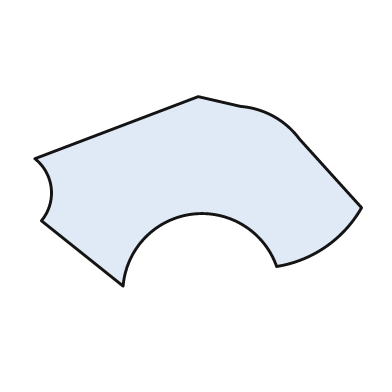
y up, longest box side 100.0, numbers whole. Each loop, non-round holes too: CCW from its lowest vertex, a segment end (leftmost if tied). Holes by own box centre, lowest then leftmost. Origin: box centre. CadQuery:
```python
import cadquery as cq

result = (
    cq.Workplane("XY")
    .moveTo(-23.0, -29.0)
    .threePointArc((-2.0, -7.0), (24.0, -23.0))
    .threePointArc((39.0, -17.0), (50.0, -5.0))
    .lineTo(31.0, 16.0)
    .threePointArc((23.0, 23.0), (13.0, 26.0))
    .lineTo(0.0, 29.0)
    .lineTo(-50.0, 10.0)
    .threePointArc((-45.0, 1.0), (-48.0, -9.0))
    .close()
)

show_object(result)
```